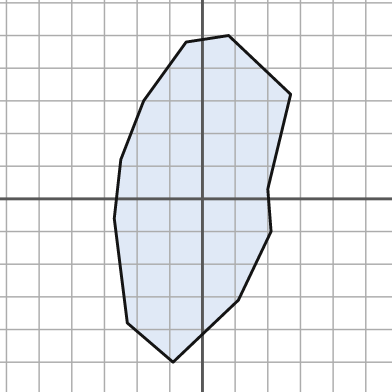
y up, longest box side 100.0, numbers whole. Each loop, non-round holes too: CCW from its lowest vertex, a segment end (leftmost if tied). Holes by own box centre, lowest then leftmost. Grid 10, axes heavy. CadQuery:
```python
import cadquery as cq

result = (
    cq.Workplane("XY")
    .moveTo(-9.0, -50.0)
    .lineTo(11.0, -31.0)
    .lineTo(21.0, -10.0)
    .lineTo(20.0, 3.0)
    .lineTo(27.0, 32.0)
    .lineTo(8.0, 50.0)
    .lineTo(-5.0, 48.0)
    .lineTo(-18.0, 30.0)
    .lineTo(-25.0, 12.0)
    .lineTo(-27.0, -6.0)
    .lineTo(-23.0, -38.0)
    .close()
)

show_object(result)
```